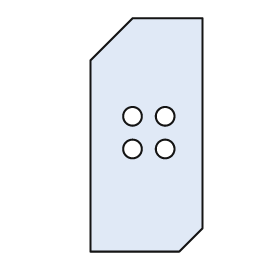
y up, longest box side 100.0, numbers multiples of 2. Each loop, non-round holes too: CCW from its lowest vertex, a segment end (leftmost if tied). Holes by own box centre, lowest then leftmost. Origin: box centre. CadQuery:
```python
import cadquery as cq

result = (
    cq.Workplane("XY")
    .moveTo(-24.0, -50.0)
    .lineTo(14.0, -50.0)
    .lineTo(24.0, -40.0)
    .lineTo(24.0, 50.0)
    .lineTo(-6.0, 50.0)
    .lineTo(-24.0, 32.0)
    .close()
    .moveTo(-6.0, -6.0)
    .circle(4.0)
    .moveTo(8.0, -6.0)
    .circle(4.0)
    .moveTo(-6.0, 8.0)
    .circle(4.0)
    .moveTo(8.0, 8.0)
    .circle(4.0)
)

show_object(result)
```